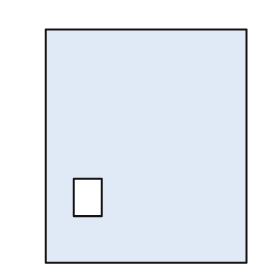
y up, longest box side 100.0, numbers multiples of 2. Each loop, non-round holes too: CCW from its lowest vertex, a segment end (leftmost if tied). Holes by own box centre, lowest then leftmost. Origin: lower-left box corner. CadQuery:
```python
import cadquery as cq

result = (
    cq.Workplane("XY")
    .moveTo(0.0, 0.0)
    .lineTo(86.0, 0.0)
    .lineTo(86.0, 100.0)
    .lineTo(0.0, 100.0)
    .close()
    .moveTo(12.0, 20.0)
    .lineTo(24.0, 20.0)
    .lineTo(24.0, 36.0)
    .lineTo(12.0, 36.0)
    .close()
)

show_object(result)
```